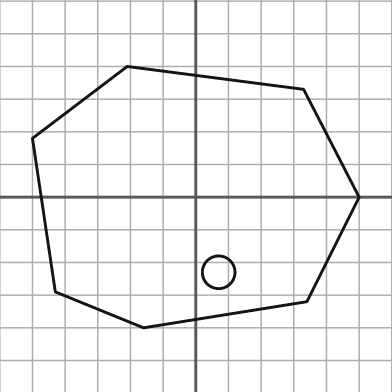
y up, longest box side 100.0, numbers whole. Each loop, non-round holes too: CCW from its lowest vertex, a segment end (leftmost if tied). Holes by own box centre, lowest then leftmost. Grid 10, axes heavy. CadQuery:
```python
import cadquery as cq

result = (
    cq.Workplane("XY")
    .moveTo(-16.0, -40.0)
    .lineTo(34.0, -32.0)
    .lineTo(50.0, 0.0)
    .lineTo(33.0, 33.0)
    .lineTo(-21.0, 40.0)
    .lineTo(-50.0, 18.0)
    .lineTo(-43.0, -29.0)
    .close()
    .moveTo(7.0, -23.0)
    .circle(5.0)
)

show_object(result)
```